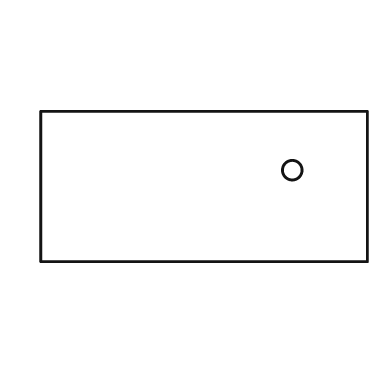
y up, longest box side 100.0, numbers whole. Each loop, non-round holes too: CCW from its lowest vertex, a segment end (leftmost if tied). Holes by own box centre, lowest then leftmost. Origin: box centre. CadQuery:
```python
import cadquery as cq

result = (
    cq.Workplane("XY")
    .moveTo(-50.0, -23.0)
    .lineTo(50.0, -23.0)
    .lineTo(50.0, 23.0)
    .lineTo(-50.0, 23.0)
    .close()
    .moveTo(27.0, 5.0)
    .circle(3.0)
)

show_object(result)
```